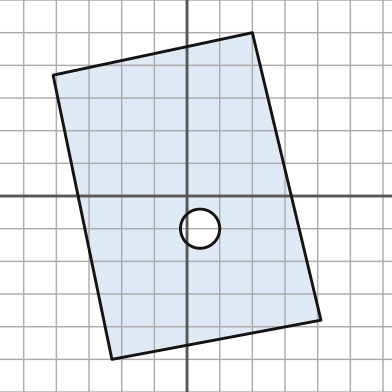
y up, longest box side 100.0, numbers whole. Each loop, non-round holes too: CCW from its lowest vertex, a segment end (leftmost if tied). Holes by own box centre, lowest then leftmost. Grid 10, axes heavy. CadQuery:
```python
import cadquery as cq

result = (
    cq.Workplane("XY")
    .moveTo(-23.0, -50.0)
    .lineTo(41.0, -38.0)
    .lineTo(20.0, 50.0)
    .lineTo(-41.0, 37.0)
    .close()
    .moveTo(4.0, -10.0)
    .circle(6.0)
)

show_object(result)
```